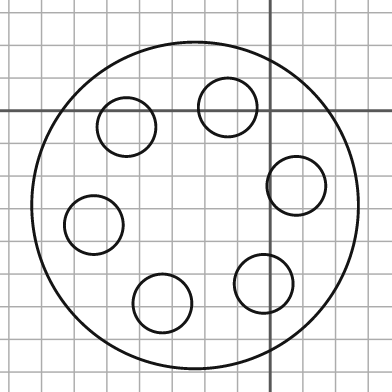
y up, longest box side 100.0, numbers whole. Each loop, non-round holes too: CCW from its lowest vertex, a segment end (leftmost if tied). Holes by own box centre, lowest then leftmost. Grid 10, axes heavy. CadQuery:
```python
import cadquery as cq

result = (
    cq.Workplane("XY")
    .moveTo(-23.0, -29.0)
    .circle(50.0)
    .moveTo(-33.0, -59.0)
    .circle(9.0)
    .moveTo(-2.0, -53.0)
    .circle(9.0)
    .moveTo(-54.0, -35.0)
    .circle(9.0)
    .moveTo(8.0, -23.0)
    .circle(9.0)
    .moveTo(-44.0, -5.0)
    .circle(9.0)
    .moveTo(-13.0, 1.0)
    .circle(9.0)
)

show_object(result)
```